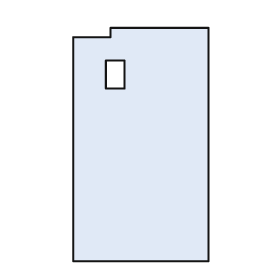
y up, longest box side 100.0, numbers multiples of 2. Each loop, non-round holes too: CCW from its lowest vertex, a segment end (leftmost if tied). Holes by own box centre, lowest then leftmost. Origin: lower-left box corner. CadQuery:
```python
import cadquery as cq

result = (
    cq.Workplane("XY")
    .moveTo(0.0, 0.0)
    .lineTo(58.0, 0.0)
    .lineTo(58.0, 100.0)
    .lineTo(16.0, 100.0)
    .lineTo(16.0, 96.0)
    .lineTo(0.0, 96.0)
    .close()
    .moveTo(14.0, 74.0)
    .lineTo(22.0, 74.0)
    .lineTo(22.0, 86.0)
    .lineTo(14.0, 86.0)
    .close()
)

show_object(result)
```